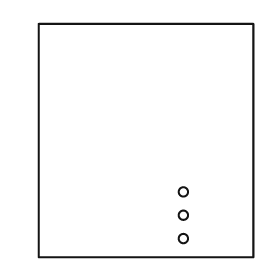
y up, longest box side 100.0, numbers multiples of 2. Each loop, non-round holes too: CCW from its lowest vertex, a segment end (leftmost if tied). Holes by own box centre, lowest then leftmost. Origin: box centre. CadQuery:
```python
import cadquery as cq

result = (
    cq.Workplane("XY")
    .moveTo(-46.0, -50.0)
    .lineTo(46.0, -50.0)
    .lineTo(46.0, 50.0)
    .lineTo(-46.0, 50.0)
    .close()
    .moveTo(16.0, -42.0)
    .circle(2.0)
    .moveTo(16.0, -32.0)
    .circle(2.0)
    .moveTo(16.0, -22.0)
    .circle(2.0)
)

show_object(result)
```